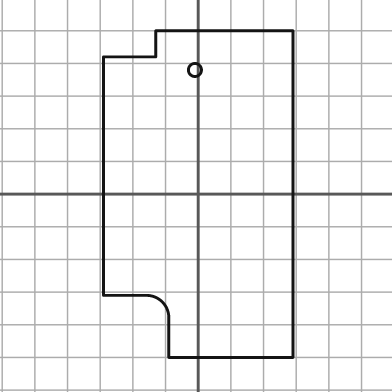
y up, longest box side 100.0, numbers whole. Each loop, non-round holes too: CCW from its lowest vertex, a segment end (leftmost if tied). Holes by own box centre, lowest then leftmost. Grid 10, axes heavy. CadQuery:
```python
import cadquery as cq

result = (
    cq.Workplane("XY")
    .moveTo(-9.0, -50.0)
    .lineTo(29.0, -50.0)
    .lineTo(29.0, 50.0)
    .lineTo(-13.0, 50.0)
    .lineTo(-13.0, 42.0)
    .lineTo(-29.0, 42.0)
    .lineTo(-29.0, -31.0)
    .lineTo(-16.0, -31.0)
    .threePointArc((-11.0, -33.0), (-9.0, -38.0))
    .close()
    .moveTo(-1.0, 38.0)
    .circle(2.0)
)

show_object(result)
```